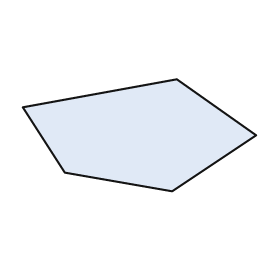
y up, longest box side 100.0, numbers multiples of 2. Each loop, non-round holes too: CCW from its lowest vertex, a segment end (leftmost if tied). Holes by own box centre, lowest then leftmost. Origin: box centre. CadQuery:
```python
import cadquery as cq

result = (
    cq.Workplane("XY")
    .moveTo(14.0, -24.0)
    .lineTo(50.0, 0.0)
    .lineTo(16.0, 24.0)
    .lineTo(-50.0, 12.0)
    .lineTo(-32.0, -16.0)
    .close()
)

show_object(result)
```